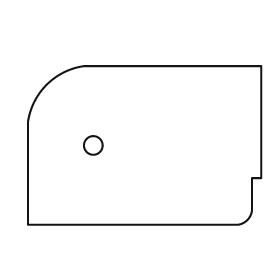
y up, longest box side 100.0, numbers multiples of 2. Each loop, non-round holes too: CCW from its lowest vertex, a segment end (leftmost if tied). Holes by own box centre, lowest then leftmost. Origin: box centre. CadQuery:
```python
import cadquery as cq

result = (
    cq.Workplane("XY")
    .moveTo(-50.0, -34.0)
    .lineTo(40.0, -34.0)
    .threePointArc((44.0, -32.0), (46.0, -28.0))
    .lineTo(46.0, -14.0)
    .lineTo(50.0, -14.0)
    .lineTo(50.0, 34.0)
    .lineTo(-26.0, 34.0)
    .threePointArc((-42.0, 26.0), (-50.0, 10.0))
    .close()
    .moveTo(-22.0, 0.0)
    .circle(4.0)
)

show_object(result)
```